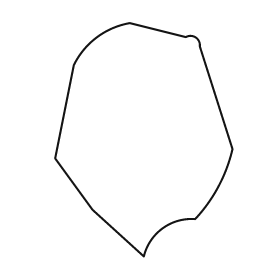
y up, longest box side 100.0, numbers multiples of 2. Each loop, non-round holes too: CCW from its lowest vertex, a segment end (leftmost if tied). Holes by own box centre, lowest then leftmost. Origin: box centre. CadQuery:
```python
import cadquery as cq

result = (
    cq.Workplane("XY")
    .moveTo(0.0, -50.0)
    .threePointArc((8.0, -38.0), (22.0, -34.0))
    .threePointArc((32.0, -20.0), (38.0, -4.0))
    .lineTo(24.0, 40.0)
    .threePointArc((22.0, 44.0), (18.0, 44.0))
    .lineTo(-6.0, 50.0)
    .threePointArc((-20.0, 44.0), (-30.0, 32.0))
    .lineTo(-38.0, -8.0)
    .lineTo(-22.0, -30.0)
    .close()
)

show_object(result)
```